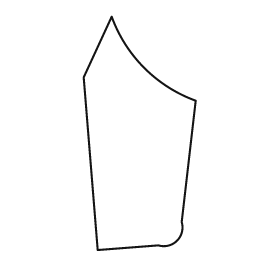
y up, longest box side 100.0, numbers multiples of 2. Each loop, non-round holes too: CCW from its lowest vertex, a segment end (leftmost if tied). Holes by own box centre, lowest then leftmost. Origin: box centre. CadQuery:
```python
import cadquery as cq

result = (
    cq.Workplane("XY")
    .moveTo(-18.0, -50.0)
    .lineTo(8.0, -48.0)
    .threePointArc((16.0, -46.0), (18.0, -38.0))
    .lineTo(24.0, 14.0)
    .threePointArc((2.0, 28.0), (-12.0, 50.0))
    .lineTo(-24.0, 24.0)
    .close()
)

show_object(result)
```